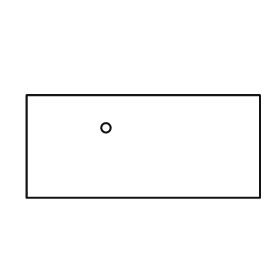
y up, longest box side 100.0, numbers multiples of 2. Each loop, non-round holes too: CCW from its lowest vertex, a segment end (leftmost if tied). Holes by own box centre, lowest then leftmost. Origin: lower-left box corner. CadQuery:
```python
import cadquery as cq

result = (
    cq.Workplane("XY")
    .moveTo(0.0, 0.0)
    .lineTo(100.0, 0.0)
    .lineTo(100.0, 44.0)
    .lineTo(0.0, 44.0)
    .close()
    .moveTo(34.0, 30.0)
    .circle(2.0)
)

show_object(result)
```